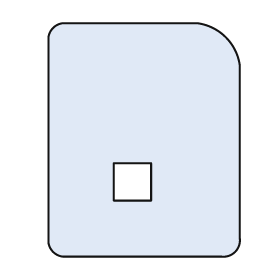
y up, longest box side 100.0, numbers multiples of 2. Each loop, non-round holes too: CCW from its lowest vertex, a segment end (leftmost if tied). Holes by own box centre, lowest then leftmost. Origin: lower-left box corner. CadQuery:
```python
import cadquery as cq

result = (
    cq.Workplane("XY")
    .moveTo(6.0, 0.0)
    .lineTo(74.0, 0.0)
    .threePointArc((80.0, 2.0), (82.0, 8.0))
    .lineTo(82.0, 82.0)
    .threePointArc((76.0, 94.0), (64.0, 100.0))
    .lineTo(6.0, 100.0)
    .threePointArc((2.0, 98.0), (0.0, 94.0))
    .lineTo(0.0, 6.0)
    .threePointArc((2.0, 2.0), (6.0, 0.0))
    .close()
    .moveTo(28.0, 24.0)
    .lineTo(44.0, 24.0)
    .lineTo(44.0, 40.0)
    .lineTo(28.0, 40.0)
    .close()
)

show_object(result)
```